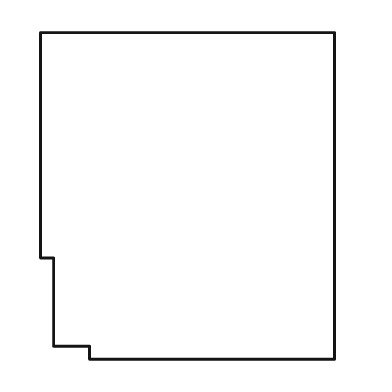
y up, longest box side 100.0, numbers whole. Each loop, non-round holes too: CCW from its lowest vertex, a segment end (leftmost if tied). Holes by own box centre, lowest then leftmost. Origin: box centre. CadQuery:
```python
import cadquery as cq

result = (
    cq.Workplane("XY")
    .moveTo(-30.0, -50.0)
    .lineTo(45.0, -50.0)
    .lineTo(45.0, 50.0)
    .lineTo(-45.0, 50.0)
    .lineTo(-45.0, -19.0)
    .lineTo(-41.0, -19.0)
    .lineTo(-41.0, -46.0)
    .lineTo(-30.0, -46.0)
    .close()
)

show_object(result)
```